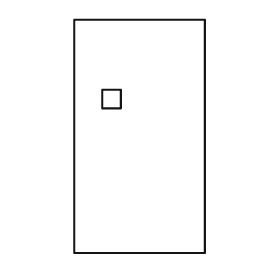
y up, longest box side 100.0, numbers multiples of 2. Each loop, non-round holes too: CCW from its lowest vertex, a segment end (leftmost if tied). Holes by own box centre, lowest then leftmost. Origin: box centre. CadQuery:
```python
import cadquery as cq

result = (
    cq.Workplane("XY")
    .moveTo(-28.0, -50.0)
    .lineTo(28.0, -50.0)
    .lineTo(28.0, 50.0)
    .lineTo(-28.0, 50.0)
    .close()
    .moveTo(-16.0, 12.0)
    .lineTo(-8.0, 12.0)
    .lineTo(-8.0, 20.0)
    .lineTo(-16.0, 20.0)
    .close()
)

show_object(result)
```